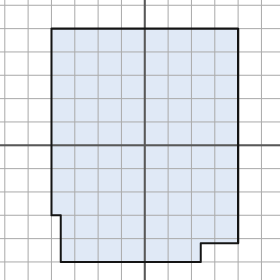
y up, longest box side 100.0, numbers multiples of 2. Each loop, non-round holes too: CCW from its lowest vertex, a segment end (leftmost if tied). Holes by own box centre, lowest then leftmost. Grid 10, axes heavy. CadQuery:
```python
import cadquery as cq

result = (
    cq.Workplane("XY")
    .moveTo(-36.0, -50.0)
    .lineTo(24.0, -50.0)
    .lineTo(24.0, -42.0)
    .lineTo(40.0, -42.0)
    .lineTo(40.0, 50.0)
    .lineTo(-40.0, 50.0)
    .lineTo(-40.0, -30.0)
    .lineTo(-36.0, -30.0)
    .close()
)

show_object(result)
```